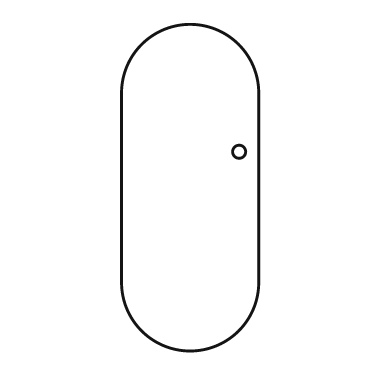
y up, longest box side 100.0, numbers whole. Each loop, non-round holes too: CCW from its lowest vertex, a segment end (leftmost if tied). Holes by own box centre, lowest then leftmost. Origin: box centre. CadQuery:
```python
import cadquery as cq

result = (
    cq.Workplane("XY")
    .moveTo(-21.0, -29.0)
    .threePointArc((0.0, -50.0), (21.0, -29.0))
    .lineTo(21.0, 29.0)
    .threePointArc((0.0, 50.0), (-21.0, 29.0))
    .close()
    .moveTo(15.0, 11.0)
    .circle(2.0)
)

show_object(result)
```